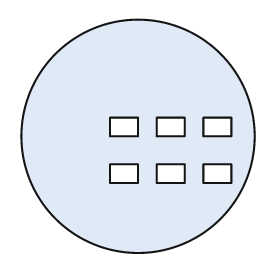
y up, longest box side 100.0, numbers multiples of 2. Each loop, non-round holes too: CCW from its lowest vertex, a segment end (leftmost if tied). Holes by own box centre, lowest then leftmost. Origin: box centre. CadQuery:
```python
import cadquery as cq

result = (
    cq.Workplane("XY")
    .moveTo(0.0, 0.0)
    .circle(50.0)
    .moveTo(-12.0, -20.0)
    .lineTo(0.0, -20.0)
    .lineTo(0.0, -12.0)
    .lineTo(-12.0, -12.0)
    .close()
    .moveTo(8.0, -20.0)
    .lineTo(20.0, -20.0)
    .lineTo(20.0, -12.0)
    .lineTo(8.0, -12.0)
    .close()
    .moveTo(28.0, -20.0)
    .lineTo(40.0, -20.0)
    .lineTo(40.0, -12.0)
    .lineTo(28.0, -12.0)
    .close()
    .moveTo(-12.0, 0.0)
    .lineTo(0.0, 0.0)
    .lineTo(0.0, 8.0)
    .lineTo(-12.0, 8.0)
    .close()
    .moveTo(8.0, 0.0)
    .lineTo(20.0, 0.0)
    .lineTo(20.0, 8.0)
    .lineTo(8.0, 8.0)
    .close()
    .moveTo(28.0, 0.0)
    .lineTo(40.0, 0.0)
    .lineTo(40.0, 8.0)
    .lineTo(28.0, 8.0)
    .close()
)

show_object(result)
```